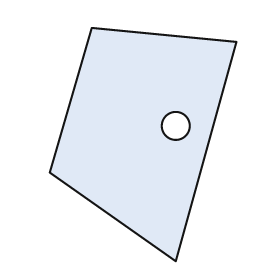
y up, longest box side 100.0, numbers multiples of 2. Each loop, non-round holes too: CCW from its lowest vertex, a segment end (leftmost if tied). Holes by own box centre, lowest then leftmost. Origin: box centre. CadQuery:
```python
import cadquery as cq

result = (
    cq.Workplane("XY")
    .moveTo(14.0, -50.0)
    .lineTo(40.0, 44.0)
    .lineTo(-22.0, 50.0)
    .lineTo(-40.0, -12.0)
    .close()
    .moveTo(14.0, 8.0)
    .circle(6.0)
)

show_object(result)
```